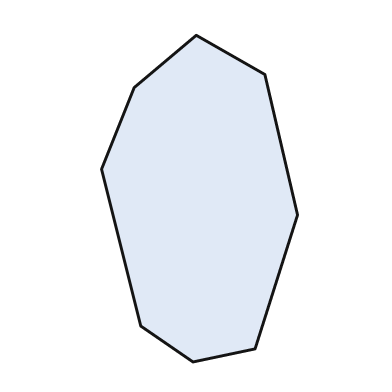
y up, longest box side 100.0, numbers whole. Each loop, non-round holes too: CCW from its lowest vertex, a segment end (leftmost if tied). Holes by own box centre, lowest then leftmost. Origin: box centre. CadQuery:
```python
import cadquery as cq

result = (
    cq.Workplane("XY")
    .moveTo(-2.0, -50.0)
    .lineTo(17.0, -46.0)
    .lineTo(30.0, -5.0)
    .lineTo(20.0, 38.0)
    .lineTo(-1.0, 50.0)
    .lineTo(-20.0, 34.0)
    .lineTo(-30.0, 9.0)
    .lineTo(-18.0, -39.0)
    .close()
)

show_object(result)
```